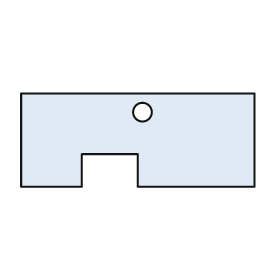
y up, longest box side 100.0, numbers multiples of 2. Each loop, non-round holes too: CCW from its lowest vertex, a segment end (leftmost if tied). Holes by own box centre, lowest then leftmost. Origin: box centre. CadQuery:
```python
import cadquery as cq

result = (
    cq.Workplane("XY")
    .moveTo(-50.0, -20.0)
    .lineTo(-24.0, -20.0)
    .lineTo(-24.0, -6.0)
    .lineTo(0.0, -6.0)
    .lineTo(0.0, -20.0)
    .lineTo(50.0, -20.0)
    .lineTo(50.0, 20.0)
    .lineTo(-50.0, 20.0)
    .close()
    .moveTo(2.0, 12.0)
    .circle(4.0)
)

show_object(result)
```